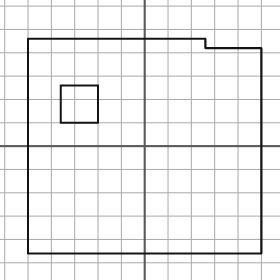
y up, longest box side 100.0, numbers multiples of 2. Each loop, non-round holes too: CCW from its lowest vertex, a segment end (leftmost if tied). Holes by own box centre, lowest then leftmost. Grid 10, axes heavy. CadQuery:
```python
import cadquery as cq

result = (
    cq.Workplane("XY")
    .moveTo(-50.0, -46.0)
    .lineTo(50.0, -46.0)
    .lineTo(50.0, 42.0)
    .lineTo(26.0, 42.0)
    .lineTo(26.0, 46.0)
    .lineTo(-50.0, 46.0)
    .close()
    .moveTo(-36.0, 10.0)
    .lineTo(-20.0, 10.0)
    .lineTo(-20.0, 26.0)
    .lineTo(-36.0, 26.0)
    .close()
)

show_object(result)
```